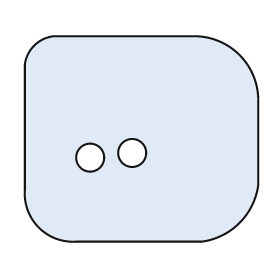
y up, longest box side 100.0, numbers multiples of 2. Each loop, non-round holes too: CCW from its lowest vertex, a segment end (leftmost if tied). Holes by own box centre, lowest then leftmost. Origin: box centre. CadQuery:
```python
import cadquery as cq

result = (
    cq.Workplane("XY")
    .moveTo(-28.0, -44.0)
    .lineTo(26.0, -44.0)
    .threePointArc((42.0, -36.0), (50.0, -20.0))
    .lineTo(50.0, 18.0)
    .threePointArc((42.0, 36.0), (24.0, 44.0))
    .lineTo(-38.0, 44.0)
    .threePointArc((-46.0, 40.0), (-50.0, 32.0))
    .lineTo(-50.0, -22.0)
    .threePointArc((-44.0, -38.0), (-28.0, -44.0))
    .close()
    .moveTo(-22.0, -8.0)
    .circle(6.0)
    .moveTo(-4.0, -6.0)
    .circle(6.0)
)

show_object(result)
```